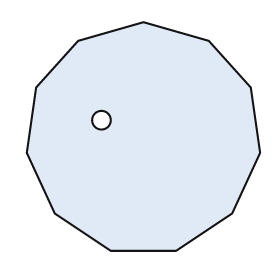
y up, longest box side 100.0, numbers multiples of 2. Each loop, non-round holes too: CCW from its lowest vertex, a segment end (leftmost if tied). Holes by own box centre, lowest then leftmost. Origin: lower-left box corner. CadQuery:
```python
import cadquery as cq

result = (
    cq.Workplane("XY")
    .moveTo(36.0, 0.0)
    .lineTo(64.0, 0.0)
    .lineTo(88.0, 16.0)
    .lineTo(100.0, 42.0)
    .lineTo(96.0, 70.0)
    .lineTo(78.0, 90.0)
    .lineTo(50.0, 98.0)
    .lineTo(22.0, 90.0)
    .lineTo(4.0, 70.0)
    .lineTo(0.0, 42.0)
    .lineTo(12.0, 16.0)
    .close()
    .moveTo(32.0, 56.0)
    .circle(4.0)
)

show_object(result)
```